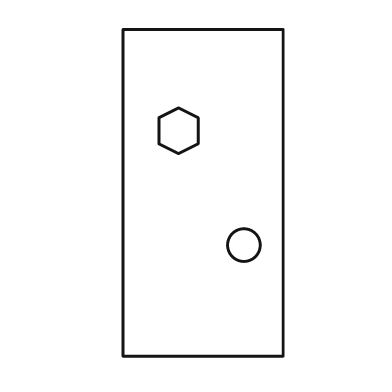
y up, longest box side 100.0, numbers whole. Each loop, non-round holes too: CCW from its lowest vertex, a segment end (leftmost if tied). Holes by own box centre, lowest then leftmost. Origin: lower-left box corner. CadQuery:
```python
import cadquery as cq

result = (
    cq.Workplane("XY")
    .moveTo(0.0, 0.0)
    .lineTo(49.0, 0.0)
    .lineTo(49.0, 100.0)
    .lineTo(0.0, 100.0)
    .close()
    .moveTo(37.0, 34.0)
    .circle(5.0)
    .moveTo(17.0, 62.0)
    .lineTo(23.0, 65.0)
    .lineTo(23.0, 73.0)
    .lineTo(17.0, 76.0)
    .lineTo(11.0, 73.0)
    .lineTo(11.0, 65.0)
    .close()
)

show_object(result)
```